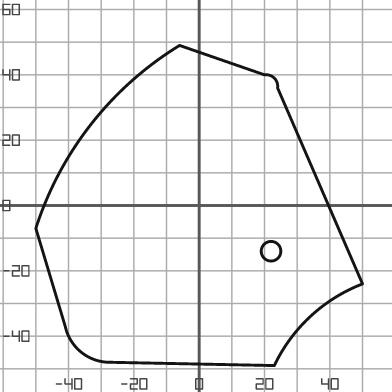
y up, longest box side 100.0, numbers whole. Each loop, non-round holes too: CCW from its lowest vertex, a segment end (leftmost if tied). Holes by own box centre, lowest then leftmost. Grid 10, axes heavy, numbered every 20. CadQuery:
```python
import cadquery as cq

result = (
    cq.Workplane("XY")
    .moveTo(23.0, -49.0)
    .threePointArc((34.0, -34.0), (50.0, -24.0))
    .lineTo(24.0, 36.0)
    .threePointArc((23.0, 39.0), (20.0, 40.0))
    .lineTo(-6.0, 49.0)
    .threePointArc((-33.0, 25.0), (-50.0, -7.0))
    .lineTo(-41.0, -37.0)
    .threePointArc((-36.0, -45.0), (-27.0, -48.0))
    .close()
    .moveTo(22.0, -14.0)
    .circle(3.0)
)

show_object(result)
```